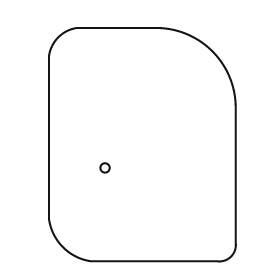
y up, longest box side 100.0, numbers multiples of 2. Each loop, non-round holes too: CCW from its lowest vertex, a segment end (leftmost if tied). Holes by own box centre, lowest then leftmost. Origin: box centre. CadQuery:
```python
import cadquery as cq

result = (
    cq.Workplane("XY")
    .moveTo(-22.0, -50.0)
    .lineTo(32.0, -50.0)
    .threePointArc((38.0, -48.0), (40.0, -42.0))
    .lineTo(40.0, 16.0)
    .threePointArc((30.0, 40.0), (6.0, 50.0))
    .lineTo(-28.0, 50.0)
    .threePointArc((-36.0, 46.0), (-40.0, 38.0))
    .lineTo(-40.0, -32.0)
    .threePointArc((-34.0, -44.0), (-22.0, -50.0))
    .close()
    .moveTo(-16.0, -10.0)
    .circle(2.0)
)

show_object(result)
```